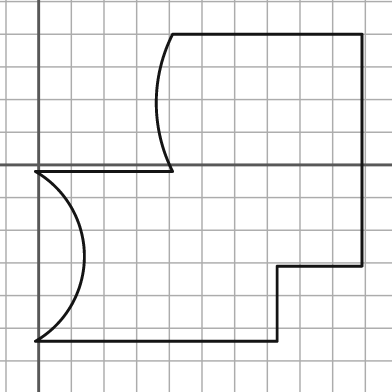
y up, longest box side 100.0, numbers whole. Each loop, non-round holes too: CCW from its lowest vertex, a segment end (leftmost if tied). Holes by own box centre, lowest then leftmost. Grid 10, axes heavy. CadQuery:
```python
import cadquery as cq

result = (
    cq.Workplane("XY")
    .moveTo(-1.0, -54.0)
    .lineTo(73.0, -54.0)
    .lineTo(73.0, -31.0)
    .lineTo(99.0, -31.0)
    .lineTo(99.0, 40.0)
    .lineTo(41.0, 40.0)
    .threePointArc((36.0, 19.0), (41.0, -2.0))
    .lineTo(-1.0, -2.0)
    .threePointArc((14.0, -28.0), (-1.0, -54.0))
    .close()
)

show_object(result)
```